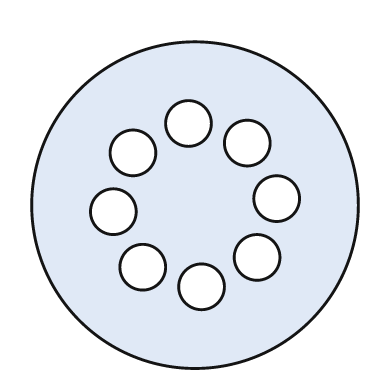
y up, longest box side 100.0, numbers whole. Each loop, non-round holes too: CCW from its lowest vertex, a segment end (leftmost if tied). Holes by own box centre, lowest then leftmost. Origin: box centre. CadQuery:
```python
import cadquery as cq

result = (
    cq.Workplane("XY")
    .moveTo(0.0, 0.0)
    .circle(50.0)
    .moveTo(2.0, -25.0)
    .circle(7.0)
    .moveTo(-16.0, -19.0)
    .circle(7.0)
    .moveTo(19.0, -16.0)
    .circle(7.0)
    .moveTo(-25.0, -2.0)
    .circle(7.0)
    .moveTo(25.0, 2.0)
    .circle(7.0)
    .moveTo(-19.0, 16.0)
    .circle(7.0)
    .moveTo(16.0, 19.0)
    .circle(7.0)
    .moveTo(-2.0, 25.0)
    .circle(7.0)
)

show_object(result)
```